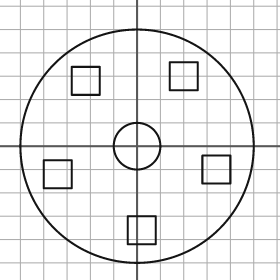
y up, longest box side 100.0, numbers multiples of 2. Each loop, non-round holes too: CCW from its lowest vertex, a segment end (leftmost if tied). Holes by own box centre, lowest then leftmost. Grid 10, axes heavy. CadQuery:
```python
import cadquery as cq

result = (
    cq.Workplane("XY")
    .moveTo(0.0, 0.0)
    .circle(50.0)
    .moveTo(-4.0, -42.0)
    .lineTo(8.0, -42.0)
    .lineTo(8.0, -30.0)
    .lineTo(-4.0, -30.0)
    .close()
    .moveTo(-40.0, -18.0)
    .lineTo(-28.0, -18.0)
    .lineTo(-28.0, -6.0)
    .lineTo(-40.0, -6.0)
    .close()
    .moveTo(28.0, -16.0)
    .lineTo(40.0, -16.0)
    .lineTo(40.0, -4.0)
    .lineTo(28.0, -4.0)
    .close()
    .moveTo(0.0, 0.0)
    .circle(10.0)
    .moveTo(-28.0, 22.0)
    .lineTo(-16.0, 22.0)
    .lineTo(-16.0, 34.0)
    .lineTo(-28.0, 34.0)
    .close()
    .moveTo(14.0, 24.0)
    .lineTo(26.0, 24.0)
    .lineTo(26.0, 36.0)
    .lineTo(14.0, 36.0)
    .close()
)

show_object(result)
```